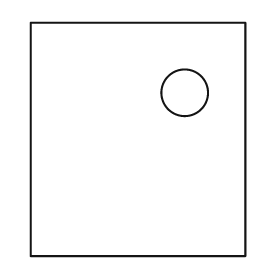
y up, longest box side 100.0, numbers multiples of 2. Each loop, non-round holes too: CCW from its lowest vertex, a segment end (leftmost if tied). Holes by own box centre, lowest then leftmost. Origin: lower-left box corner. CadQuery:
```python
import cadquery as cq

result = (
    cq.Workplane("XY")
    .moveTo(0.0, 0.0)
    .lineTo(92.0, 0.0)
    .lineTo(92.0, 100.0)
    .lineTo(0.0, 100.0)
    .close()
    .moveTo(66.0, 70.0)
    .circle(10.0)
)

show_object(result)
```